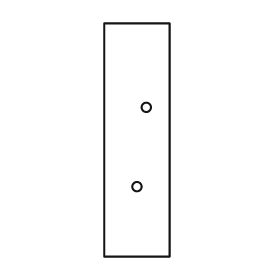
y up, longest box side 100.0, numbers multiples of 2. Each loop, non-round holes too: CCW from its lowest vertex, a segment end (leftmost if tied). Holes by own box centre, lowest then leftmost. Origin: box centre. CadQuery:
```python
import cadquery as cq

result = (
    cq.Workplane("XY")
    .moveTo(-14.0, -50.0)
    .lineTo(14.0, -50.0)
    .lineTo(14.0, 50.0)
    .lineTo(-14.0, 50.0)
    .close()
    .moveTo(0.0, -20.0)
    .circle(2.0)
    .moveTo(4.0, 14.0)
    .circle(2.0)
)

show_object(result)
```